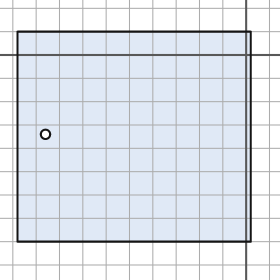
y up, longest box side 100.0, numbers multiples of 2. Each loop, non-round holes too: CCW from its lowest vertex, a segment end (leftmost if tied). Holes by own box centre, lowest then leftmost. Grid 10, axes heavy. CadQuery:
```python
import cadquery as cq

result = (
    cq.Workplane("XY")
    .moveTo(-98.0, -80.0)
    .lineTo(2.0, -80.0)
    .lineTo(2.0, 10.0)
    .lineTo(-98.0, 10.0)
    .close()
    .moveTo(-86.0, -34.0)
    .circle(2.0)
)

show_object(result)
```